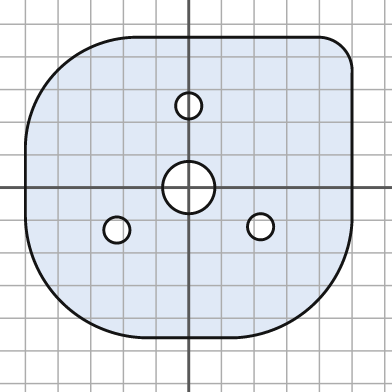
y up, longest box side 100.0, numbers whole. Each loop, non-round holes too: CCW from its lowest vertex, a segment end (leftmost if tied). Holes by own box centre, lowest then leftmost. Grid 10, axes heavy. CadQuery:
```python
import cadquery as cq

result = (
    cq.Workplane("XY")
    .moveTo(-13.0, -46.0)
    .lineTo(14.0, -46.0)
    .threePointArc((39.0, -35.0), (50.0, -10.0))
    .lineTo(50.0, 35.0)
    .threePointArc((47.0, 43.0), (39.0, 46.0))
    .lineTo(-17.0, 46.0)
    .threePointArc((-40.0, 36.0), (-50.0, 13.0))
    .lineTo(-50.0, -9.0)
    .threePointArc((-39.0, -35.0), (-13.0, -46.0))
    .close()
    .moveTo(-22.0, -13.0)
    .circle(4.0)
    .moveTo(22.0, -12.0)
    .circle(4.0)
    .moveTo(0.0, 0.0)
    .circle(8.0)
    .moveTo(0.0, 25.0)
    .circle(4.0)
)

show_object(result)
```